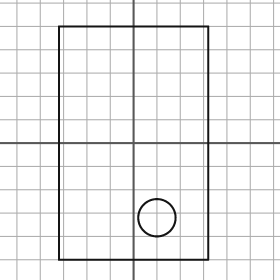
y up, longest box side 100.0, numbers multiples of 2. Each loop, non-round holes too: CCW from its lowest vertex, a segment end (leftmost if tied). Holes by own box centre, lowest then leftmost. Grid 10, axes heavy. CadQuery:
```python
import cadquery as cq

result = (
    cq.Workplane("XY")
    .moveTo(-32.0, -50.0)
    .lineTo(32.0, -50.0)
    .lineTo(32.0, 50.0)
    .lineTo(-32.0, 50.0)
    .close()
    .moveTo(10.0, -32.0)
    .circle(8.0)
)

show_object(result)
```